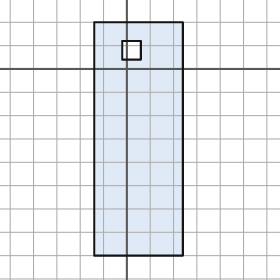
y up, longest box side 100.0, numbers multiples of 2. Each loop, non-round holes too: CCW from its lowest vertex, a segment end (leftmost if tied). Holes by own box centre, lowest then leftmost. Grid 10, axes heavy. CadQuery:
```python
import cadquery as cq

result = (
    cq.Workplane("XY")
    .moveTo(-14.0, -80.0)
    .lineTo(24.0, -80.0)
    .lineTo(24.0, 20.0)
    .lineTo(-14.0, 20.0)
    .close()
    .moveTo(-2.0, 4.0)
    .lineTo(6.0, 4.0)
    .lineTo(6.0, 12.0)
    .lineTo(-2.0, 12.0)
    .close()
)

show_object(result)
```